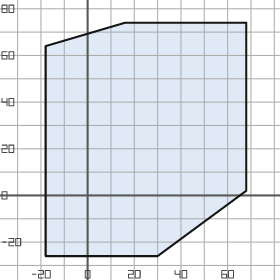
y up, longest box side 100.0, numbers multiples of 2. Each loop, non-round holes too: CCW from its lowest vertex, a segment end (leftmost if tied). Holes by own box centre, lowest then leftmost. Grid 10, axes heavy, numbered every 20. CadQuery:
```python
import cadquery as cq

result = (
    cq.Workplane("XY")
    .moveTo(-18.0, -26.0)
    .lineTo(30.0, -26.0)
    .lineTo(68.0, 2.0)
    .lineTo(68.0, 74.0)
    .lineTo(16.0, 74.0)
    .lineTo(-18.0, 64.0)
    .close()
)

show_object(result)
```